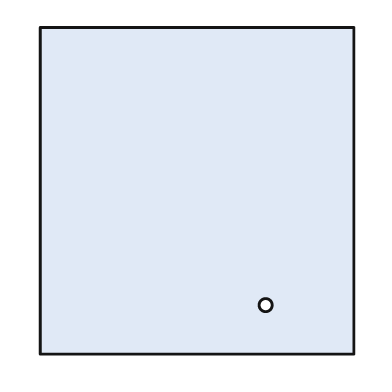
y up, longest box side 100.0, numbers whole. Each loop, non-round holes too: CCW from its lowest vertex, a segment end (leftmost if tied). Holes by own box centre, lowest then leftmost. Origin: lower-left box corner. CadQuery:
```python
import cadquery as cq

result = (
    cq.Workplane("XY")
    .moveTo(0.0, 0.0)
    .lineTo(96.0, 0.0)
    .lineTo(96.0, 100.0)
    .lineTo(0.0, 100.0)
    .close()
    .moveTo(69.0, 15.0)
    .circle(2.0)
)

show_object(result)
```